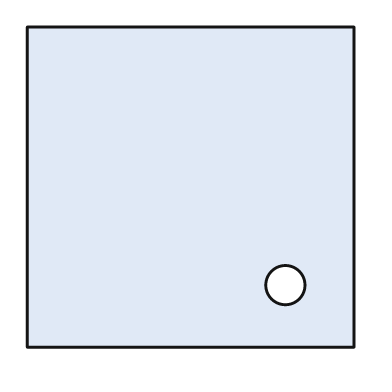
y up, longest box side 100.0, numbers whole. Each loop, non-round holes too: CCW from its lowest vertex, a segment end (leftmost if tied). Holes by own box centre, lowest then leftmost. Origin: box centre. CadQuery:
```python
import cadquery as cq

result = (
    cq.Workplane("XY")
    .moveTo(-50.0, -49.0)
    .lineTo(50.0, -49.0)
    .lineTo(50.0, 49.0)
    .lineTo(-50.0, 49.0)
    .close()
    .moveTo(29.0, -30.0)
    .circle(6.0)
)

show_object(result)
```